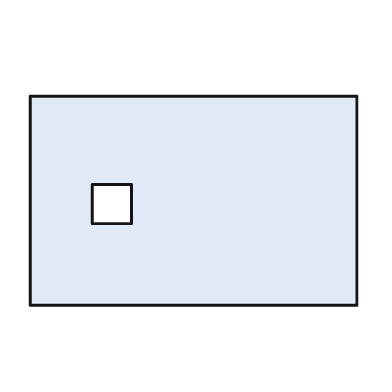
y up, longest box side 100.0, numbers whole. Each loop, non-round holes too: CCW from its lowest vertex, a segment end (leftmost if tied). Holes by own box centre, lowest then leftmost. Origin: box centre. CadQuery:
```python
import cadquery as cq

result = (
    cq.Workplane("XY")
    .moveTo(-50.0, -32.0)
    .lineTo(50.0, -32.0)
    .lineTo(50.0, 32.0)
    .lineTo(-50.0, 32.0)
    .close()
    .moveTo(-31.0, -7.0)
    .lineTo(-19.0, -7.0)
    .lineTo(-19.0, 5.0)
    .lineTo(-31.0, 5.0)
    .close()
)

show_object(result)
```